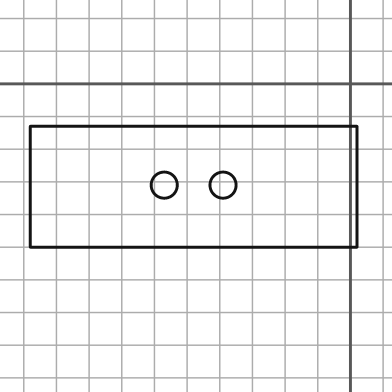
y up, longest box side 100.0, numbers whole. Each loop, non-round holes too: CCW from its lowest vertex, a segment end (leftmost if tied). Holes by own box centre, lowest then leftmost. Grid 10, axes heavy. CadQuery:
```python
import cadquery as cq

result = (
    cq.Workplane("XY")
    .moveTo(-98.0, -50.0)
    .lineTo(2.0, -50.0)
    .lineTo(2.0, -13.0)
    .lineTo(-98.0, -13.0)
    .close()
    .moveTo(-57.0, -31.0)
    .circle(4.0)
    .moveTo(-39.0, -31.0)
    .circle(4.0)
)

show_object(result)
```